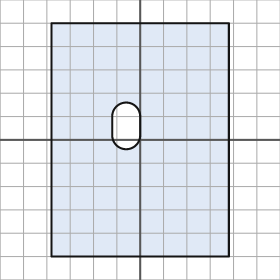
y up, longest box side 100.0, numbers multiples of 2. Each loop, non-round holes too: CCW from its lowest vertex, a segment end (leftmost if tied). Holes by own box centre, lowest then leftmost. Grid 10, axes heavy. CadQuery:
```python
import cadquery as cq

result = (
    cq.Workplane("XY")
    .moveTo(-38.0, -50.0)
    .lineTo(38.0, -50.0)
    .lineTo(38.0, 50.0)
    .lineTo(-38.0, 50.0)
    .close()
    .moveTo(-12.0, 2.0)
    .threePointArc((-6.0, -4.0), (0.0, 2.0))
    .lineTo(0.0, 10.0)
    .threePointArc((-6.0, 16.0), (-12.0, 10.0))
    .close()
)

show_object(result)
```